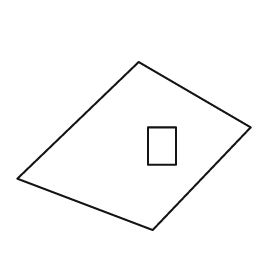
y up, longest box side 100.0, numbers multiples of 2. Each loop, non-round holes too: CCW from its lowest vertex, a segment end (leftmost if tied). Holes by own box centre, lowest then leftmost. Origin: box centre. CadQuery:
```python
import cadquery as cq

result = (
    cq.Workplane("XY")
    .moveTo(8.0, -36.0)
    .lineTo(50.0, 8.0)
    .lineTo(2.0, 36.0)
    .lineTo(-50.0, -14.0)
    .close()
    .moveTo(6.0, -8.0)
    .lineTo(18.0, -8.0)
    .lineTo(18.0, 8.0)
    .lineTo(6.0, 8.0)
    .close()
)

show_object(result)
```